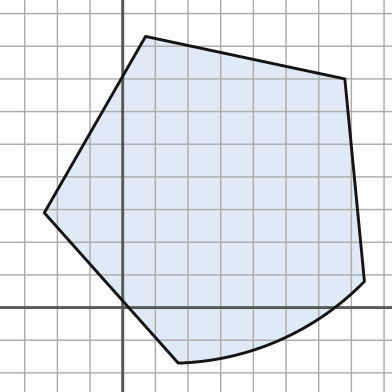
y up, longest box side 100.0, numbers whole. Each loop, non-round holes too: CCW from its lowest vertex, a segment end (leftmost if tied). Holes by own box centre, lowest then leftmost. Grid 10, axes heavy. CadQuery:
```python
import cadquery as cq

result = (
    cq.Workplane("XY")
    .moveTo(17.0, -17.0)
    .threePointArc((48.0, -10.0), (74.0, 8.0))
    .lineTo(68.0, 70.0)
    .lineTo(7.0, 83.0)
    .lineTo(-24.0, 29.0)
    .close()
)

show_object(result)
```